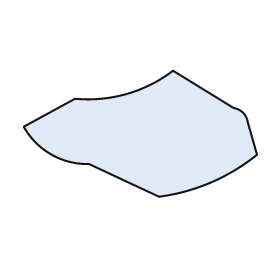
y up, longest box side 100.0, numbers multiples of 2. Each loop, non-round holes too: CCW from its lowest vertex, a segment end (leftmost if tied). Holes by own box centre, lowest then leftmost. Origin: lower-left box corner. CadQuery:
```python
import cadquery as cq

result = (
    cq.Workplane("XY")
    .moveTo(58.0, 0.0)
    .threePointArc((80.0, 6.0), (100.0, 18.0))
    .lineTo(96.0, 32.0)
    .threePointArc((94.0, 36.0), (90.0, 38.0))
    .lineTo(64.0, 54.0)
    .threePointArc((44.0, 44.0), (22.0, 42.0))
    .lineTo(0.0, 30.0)
    .threePointArc((12.0, 18.0), (28.0, 14.0))
    .close()
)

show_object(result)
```